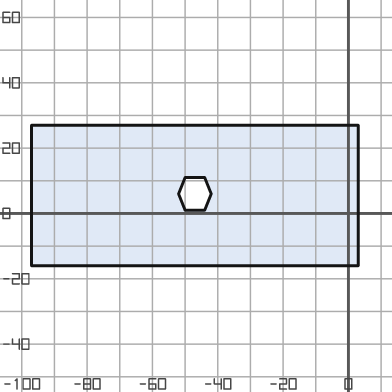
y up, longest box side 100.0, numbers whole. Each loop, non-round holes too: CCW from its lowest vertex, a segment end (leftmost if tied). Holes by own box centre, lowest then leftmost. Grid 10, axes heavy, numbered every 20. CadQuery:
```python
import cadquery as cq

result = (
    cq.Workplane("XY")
    .moveTo(-97.0, -16.0)
    .lineTo(3.0, -16.0)
    .lineTo(3.0, 27.0)
    .lineTo(-97.0, 27.0)
    .close()
    .moveTo(-50.0, 1.0)
    .lineTo(-44.0, 1.0)
    .lineTo(-42.0, 6.0)
    .lineTo(-44.0, 11.0)
    .lineTo(-50.0, 11.0)
    .lineTo(-52.0, 6.0)
    .close()
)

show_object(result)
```